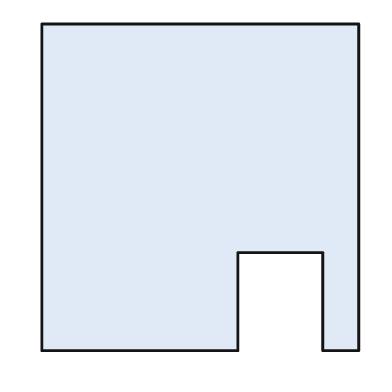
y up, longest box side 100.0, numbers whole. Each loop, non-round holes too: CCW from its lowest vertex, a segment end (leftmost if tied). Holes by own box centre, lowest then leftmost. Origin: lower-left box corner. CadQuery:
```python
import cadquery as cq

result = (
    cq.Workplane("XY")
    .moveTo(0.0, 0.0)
    .lineTo(60.0, 0.0)
    .lineTo(60.0, 30.0)
    .lineTo(86.0, 30.0)
    .lineTo(86.0, 0.0)
    .lineTo(97.0, 0.0)
    .lineTo(97.0, 100.0)
    .lineTo(0.0, 100.0)
    .close()
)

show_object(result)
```